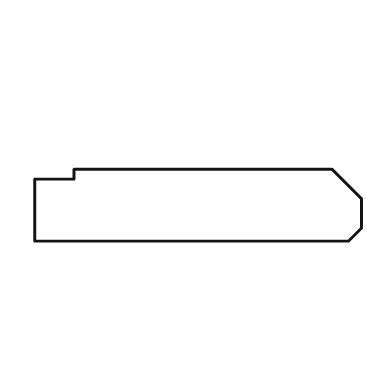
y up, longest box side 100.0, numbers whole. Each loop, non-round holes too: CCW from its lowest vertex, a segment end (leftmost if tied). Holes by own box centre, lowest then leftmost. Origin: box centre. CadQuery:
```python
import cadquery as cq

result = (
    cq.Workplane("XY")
    .moveTo(-50.0, -11.0)
    .lineTo(46.0, -11.0)
    .lineTo(50.0, -7.0)
    .lineTo(50.0, 2.0)
    .lineTo(41.0, 11.0)
    .lineTo(-38.0, 11.0)
    .lineTo(-38.0, 8.0)
    .lineTo(-50.0, 8.0)
    .close()
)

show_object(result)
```